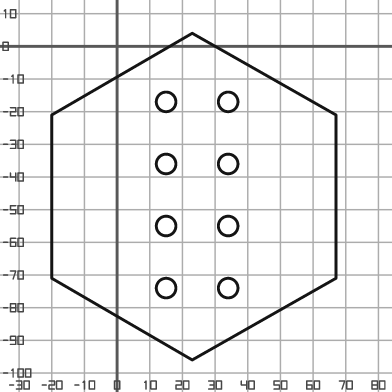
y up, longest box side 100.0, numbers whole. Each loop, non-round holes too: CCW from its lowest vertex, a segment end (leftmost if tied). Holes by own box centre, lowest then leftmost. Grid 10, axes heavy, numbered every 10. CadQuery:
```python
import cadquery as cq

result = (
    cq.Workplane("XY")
    .moveTo(23.0, -96.0)
    .lineTo(67.0, -71.0)
    .lineTo(67.0, -21.0)
    .lineTo(23.0, 4.0)
    .lineTo(-20.0, -21.0)
    .lineTo(-20.0, -71.0)
    .close()
    .moveTo(15.0, -74.0)
    .circle(3.0)
    .moveTo(34.0, -74.0)
    .circle(3.0)
    .moveTo(15.0, -55.0)
    .circle(3.0)
    .moveTo(34.0, -55.0)
    .circle(3.0)
    .moveTo(15.0, -36.0)
    .circle(3.0)
    .moveTo(34.0, -36.0)
    .circle(3.0)
    .moveTo(15.0, -17.0)
    .circle(3.0)
    .moveTo(34.0, -17.0)
    .circle(3.0)
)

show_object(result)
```